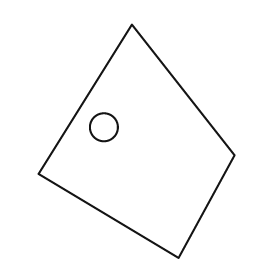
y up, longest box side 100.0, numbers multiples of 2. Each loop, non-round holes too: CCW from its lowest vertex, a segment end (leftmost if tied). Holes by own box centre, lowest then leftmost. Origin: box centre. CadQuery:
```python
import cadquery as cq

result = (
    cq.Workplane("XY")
    .moveTo(18.0, -50.0)
    .lineTo(42.0, -6.0)
    .lineTo(-2.0, 50.0)
    .lineTo(-42.0, -14.0)
    .close()
    .moveTo(-14.0, 6.0)
    .circle(6.0)
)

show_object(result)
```